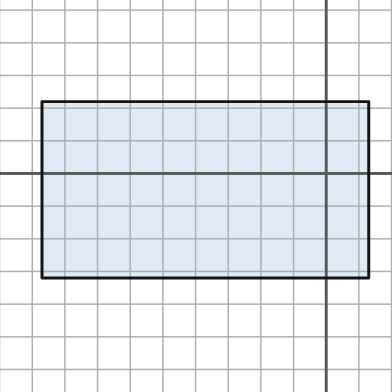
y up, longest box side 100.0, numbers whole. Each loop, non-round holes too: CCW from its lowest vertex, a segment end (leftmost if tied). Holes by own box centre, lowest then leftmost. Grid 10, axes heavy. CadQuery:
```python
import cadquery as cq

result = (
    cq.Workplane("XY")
    .moveTo(-87.0, -32.0)
    .lineTo(13.0, -32.0)
    .lineTo(13.0, 22.0)
    .lineTo(-87.0, 22.0)
    .close()
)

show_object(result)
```